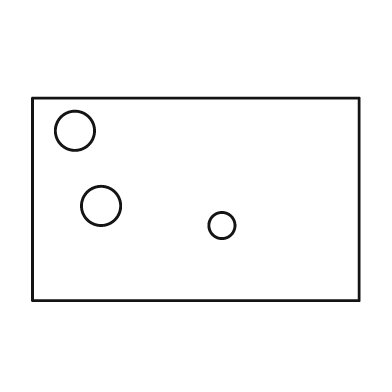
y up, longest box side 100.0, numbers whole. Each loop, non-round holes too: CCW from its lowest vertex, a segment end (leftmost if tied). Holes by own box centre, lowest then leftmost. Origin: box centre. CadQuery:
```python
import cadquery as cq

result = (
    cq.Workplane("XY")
    .moveTo(-50.0, -31.0)
    .lineTo(50.0, -31.0)
    .lineTo(50.0, 31.0)
    .lineTo(-50.0, 31.0)
    .close()
    .moveTo(8.0, -8.0)
    .circle(4.0)
    .moveTo(-29.0, -2.0)
    .circle(6.0)
    .moveTo(-37.0, 21.0)
    .circle(6.0)
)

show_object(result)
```